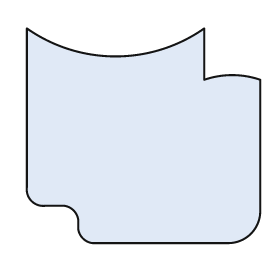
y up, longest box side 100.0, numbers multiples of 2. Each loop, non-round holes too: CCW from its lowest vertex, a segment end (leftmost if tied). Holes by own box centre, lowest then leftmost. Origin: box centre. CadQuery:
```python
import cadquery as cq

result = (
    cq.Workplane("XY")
    .moveTo(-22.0, -46.0)
    .lineTo(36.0, -46.0)
    .threePointArc((46.0, -42.0), (50.0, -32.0))
    .lineTo(50.0, 24.0)
    .threePointArc((38.0, 26.0), (26.0, 24.0))
    .lineTo(26.0, 46.0)
    .threePointArc((-12.0, 34.0), (-50.0, 46.0))
    .lineTo(-50.0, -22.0)
    .threePointArc((-48.0, -28.0), (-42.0, -30.0))
    .lineTo(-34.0, -30.0)
    .threePointArc((-30.0, -32.0), (-28.0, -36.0))
    .lineTo(-28.0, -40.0)
    .threePointArc((-26.0, -44.0), (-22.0, -46.0))
    .close()
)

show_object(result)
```